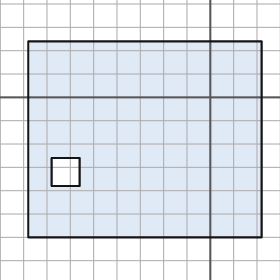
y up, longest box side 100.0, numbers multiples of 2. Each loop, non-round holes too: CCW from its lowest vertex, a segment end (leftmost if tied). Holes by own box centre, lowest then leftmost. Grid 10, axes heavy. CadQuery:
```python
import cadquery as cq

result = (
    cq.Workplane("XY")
    .moveTo(-78.0, -60.0)
    .lineTo(22.0, -60.0)
    .lineTo(22.0, 24.0)
    .lineTo(-78.0, 24.0)
    .close()
    .moveTo(-68.0, -38.0)
    .lineTo(-56.0, -38.0)
    .lineTo(-56.0, -26.0)
    .lineTo(-68.0, -26.0)
    .close()
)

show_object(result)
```